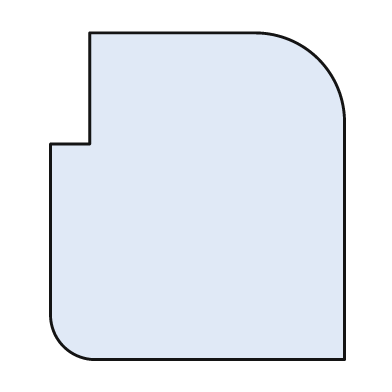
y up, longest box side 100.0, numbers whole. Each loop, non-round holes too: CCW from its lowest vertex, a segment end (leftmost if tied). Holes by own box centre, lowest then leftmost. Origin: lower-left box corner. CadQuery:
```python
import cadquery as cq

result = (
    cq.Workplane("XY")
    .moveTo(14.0, 0.0)
    .lineTo(90.0, 0.0)
    .lineTo(90.0, 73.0)
    .threePointArc((82.0, 92.0), (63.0, 100.0))
    .lineTo(12.0, 100.0)
    .lineTo(12.0, 66.0)
    .lineTo(0.0, 66.0)
    .lineTo(0.0, 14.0)
    .threePointArc((4.0, 4.0), (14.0, 0.0))
    .close()
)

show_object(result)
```